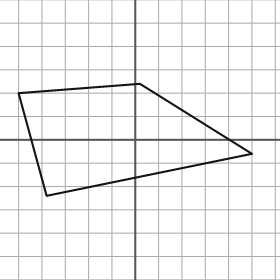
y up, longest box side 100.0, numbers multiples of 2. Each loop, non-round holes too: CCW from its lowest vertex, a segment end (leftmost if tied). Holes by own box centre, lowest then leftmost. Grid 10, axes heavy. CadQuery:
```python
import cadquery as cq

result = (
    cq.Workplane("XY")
    .moveTo(-38.0, -24.0)
    .lineTo(50.0, -6.0)
    .lineTo(2.0, 24.0)
    .lineTo(-50.0, 20.0)
    .close()
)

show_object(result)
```